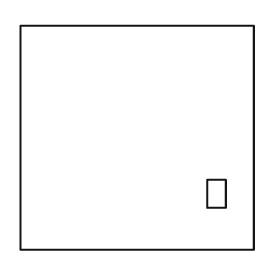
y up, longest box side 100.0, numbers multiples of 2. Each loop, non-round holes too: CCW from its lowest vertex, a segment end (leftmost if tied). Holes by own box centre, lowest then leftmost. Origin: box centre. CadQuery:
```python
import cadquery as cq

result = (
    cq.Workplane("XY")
    .moveTo(-50.0, -48.0)
    .lineTo(50.0, -48.0)
    .lineTo(50.0, 48.0)
    .lineTo(-50.0, 48.0)
    .close()
    .moveTo(30.0, -30.0)
    .lineTo(38.0, -30.0)
    .lineTo(38.0, -18.0)
    .lineTo(30.0, -18.0)
    .close()
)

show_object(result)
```